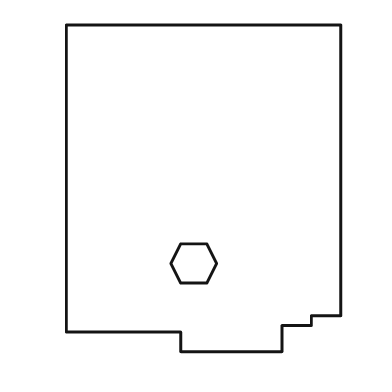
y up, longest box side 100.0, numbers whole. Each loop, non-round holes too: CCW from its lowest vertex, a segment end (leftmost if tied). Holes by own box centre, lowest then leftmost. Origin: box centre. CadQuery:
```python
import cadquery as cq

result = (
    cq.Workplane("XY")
    .moveTo(-7.0, -50.0)
    .lineTo(24.0, -50.0)
    .lineTo(24.0, -42.0)
    .lineTo(33.0, -42.0)
    .lineTo(33.0, -39.0)
    .lineTo(42.0, -39.0)
    .lineTo(42.0, 50.0)
    .lineTo(-42.0, 50.0)
    .lineTo(-42.0, -44.0)
    .lineTo(-7.0, -44.0)
    .close()
    .moveTo(-7.0, -29.0)
    .lineTo(1.0, -29.0)
    .lineTo(4.0, -23.0)
    .lineTo(1.0, -17.0)
    .lineTo(-7.0, -17.0)
    .lineTo(-10.0, -23.0)
    .close()
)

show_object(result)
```